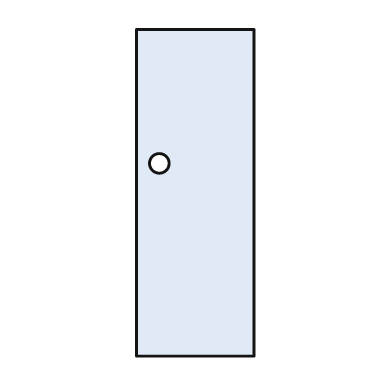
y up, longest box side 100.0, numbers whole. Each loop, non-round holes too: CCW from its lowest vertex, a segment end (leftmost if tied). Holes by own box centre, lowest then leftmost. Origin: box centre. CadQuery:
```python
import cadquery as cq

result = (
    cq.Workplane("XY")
    .moveTo(-18.0, -50.0)
    .lineTo(18.0, -50.0)
    .lineTo(18.0, 50.0)
    .lineTo(-18.0, 50.0)
    .close()
    .moveTo(-11.0, 9.0)
    .circle(3.0)
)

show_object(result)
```